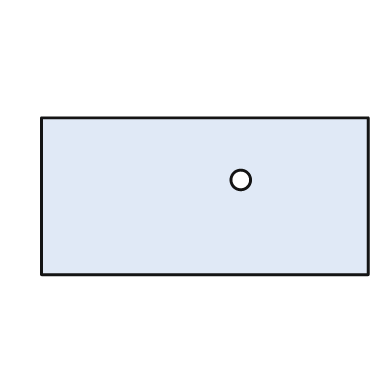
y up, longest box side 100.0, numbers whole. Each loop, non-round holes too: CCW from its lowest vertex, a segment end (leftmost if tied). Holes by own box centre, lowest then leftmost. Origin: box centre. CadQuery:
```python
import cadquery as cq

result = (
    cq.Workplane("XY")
    .moveTo(-50.0, -24.0)
    .lineTo(50.0, -24.0)
    .lineTo(50.0, 24.0)
    .lineTo(-50.0, 24.0)
    .close()
    .moveTo(11.0, 5.0)
    .circle(3.0)
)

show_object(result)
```